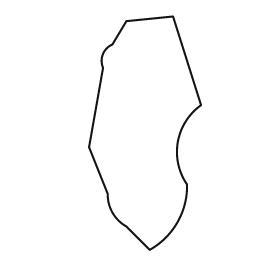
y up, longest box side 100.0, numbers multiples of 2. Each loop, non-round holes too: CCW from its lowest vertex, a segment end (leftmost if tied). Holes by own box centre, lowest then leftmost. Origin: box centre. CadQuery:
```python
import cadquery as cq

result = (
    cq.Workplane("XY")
    .moveTo(2.0, -50.0)
    .threePointArc((14.0, -38.0), (18.0, -22.0))
    .threePointArc((14.0, -4.0), (24.0, 12.0))
    .lineTo(12.0, 50.0)
    .lineTo(-8.0, 48.0)
    .lineTo(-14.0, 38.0)
    .threePointArc((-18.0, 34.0), (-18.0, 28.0))
    .lineTo(-24.0, -6.0)
    .lineTo(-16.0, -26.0)
    .threePointArc((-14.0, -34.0), (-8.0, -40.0))
    .close()
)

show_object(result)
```